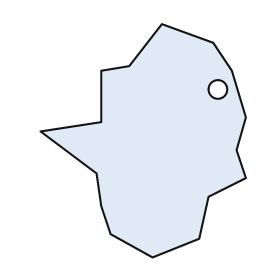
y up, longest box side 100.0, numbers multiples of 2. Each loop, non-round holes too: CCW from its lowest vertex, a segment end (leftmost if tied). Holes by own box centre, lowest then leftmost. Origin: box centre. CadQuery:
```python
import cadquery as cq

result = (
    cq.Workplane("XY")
    .moveTo(4.0, -50.0)
    .lineTo(24.0, -42.0)
    .lineTo(28.0, -24.0)
    .lineTo(44.0, -16.0)
    .lineTo(40.0, -4.0)
    .lineTo(44.0, 10.0)
    .lineTo(38.0, 30.0)
    .lineTo(30.0, 42.0)
    .lineTo(8.0, 50.0)
    .lineTo(-6.0, 32.0)
    .lineTo(-18.0, 30.0)
    .lineTo(-18.0, 8.0)
    .lineTo(-44.0, 4.0)
    .lineTo(-20.0, -14.0)
    .lineTo(-18.0, -28.0)
    .lineTo(-14.0, -40.0)
    .close()
    .moveTo(32.0, 22.0)
    .circle(4.0)
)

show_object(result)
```